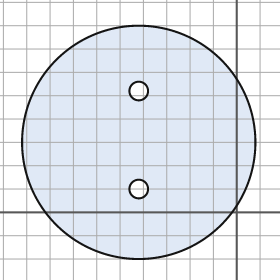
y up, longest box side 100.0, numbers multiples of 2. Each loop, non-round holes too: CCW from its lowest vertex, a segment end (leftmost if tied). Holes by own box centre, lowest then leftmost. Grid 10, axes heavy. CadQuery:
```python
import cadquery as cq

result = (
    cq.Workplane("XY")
    .moveTo(-42.0, 30.0)
    .circle(50.0)
    .moveTo(-42.0, 10.0)
    .circle(4.0)
    .moveTo(-42.0, 52.0)
    .circle(4.0)
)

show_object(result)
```